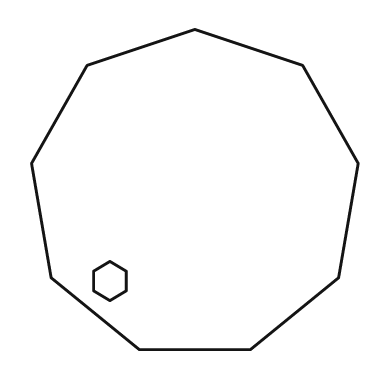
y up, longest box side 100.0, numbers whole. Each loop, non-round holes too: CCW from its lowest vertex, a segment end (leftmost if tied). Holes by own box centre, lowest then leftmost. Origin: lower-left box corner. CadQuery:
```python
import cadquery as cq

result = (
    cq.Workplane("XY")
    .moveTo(33.0, 0.0)
    .lineTo(67.0, 0.0)
    .lineTo(94.0, 22.0)
    .lineTo(100.0, 57.0)
    .lineTo(83.0, 87.0)
    .lineTo(50.0, 98.0)
    .lineTo(17.0, 87.0)
    .lineTo(0.0, 57.0)
    .lineTo(6.0, 22.0)
    .close()
    .moveTo(24.0, 15.0)
    .lineTo(29.0, 18.0)
    .lineTo(29.0, 24.0)
    .lineTo(24.0, 27.0)
    .lineTo(19.0, 24.0)
    .lineTo(19.0, 18.0)
    .close()
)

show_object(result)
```